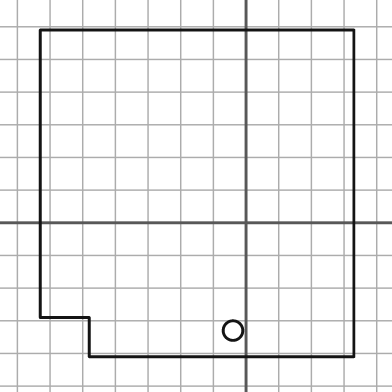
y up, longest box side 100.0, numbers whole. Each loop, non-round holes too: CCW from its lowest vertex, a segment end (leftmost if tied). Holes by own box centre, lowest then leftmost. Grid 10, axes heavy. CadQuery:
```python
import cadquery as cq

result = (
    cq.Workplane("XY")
    .moveTo(-48.0, -41.0)
    .lineTo(33.0, -41.0)
    .lineTo(33.0, 59.0)
    .lineTo(-63.0, 59.0)
    .lineTo(-63.0, -29.0)
    .lineTo(-48.0, -29.0)
    .close()
    .moveTo(-4.0, -33.0)
    .circle(3.0)
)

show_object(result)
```